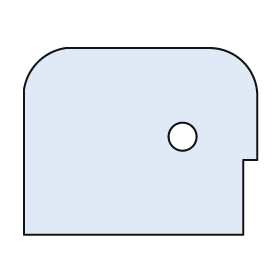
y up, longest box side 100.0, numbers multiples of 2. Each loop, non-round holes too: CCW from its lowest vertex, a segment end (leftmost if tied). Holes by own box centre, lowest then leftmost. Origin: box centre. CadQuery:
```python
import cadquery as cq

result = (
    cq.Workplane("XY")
    .moveTo(-50.0, -40.0)
    .lineTo(44.0, -40.0)
    .lineTo(44.0, -8.0)
    .lineTo(50.0, -8.0)
    .lineTo(50.0, 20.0)
    .threePointArc((44.0, 34.0), (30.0, 40.0))
    .lineTo(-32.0, 40.0)
    .threePointArc((-44.0, 34.0), (-50.0, 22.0))
    .close()
    .moveTo(18.0, 2.0)
    .circle(6.0)
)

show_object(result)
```